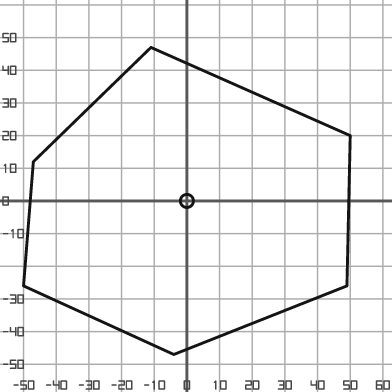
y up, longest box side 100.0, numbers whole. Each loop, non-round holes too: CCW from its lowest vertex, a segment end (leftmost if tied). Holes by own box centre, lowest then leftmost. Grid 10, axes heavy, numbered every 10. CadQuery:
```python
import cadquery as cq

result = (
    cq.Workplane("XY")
    .moveTo(-4.0, -47.0)
    .lineTo(49.0, -26.0)
    .lineTo(50.0, 20.0)
    .lineTo(-11.0, 47.0)
    .lineTo(-47.0, 12.0)
    .lineTo(-50.0, -26.0)
    .close()
    .moveTo(0.0, 0.0)
    .circle(2.0)
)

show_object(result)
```